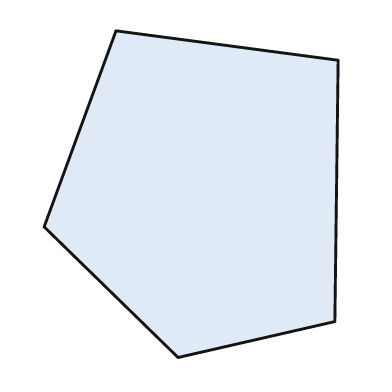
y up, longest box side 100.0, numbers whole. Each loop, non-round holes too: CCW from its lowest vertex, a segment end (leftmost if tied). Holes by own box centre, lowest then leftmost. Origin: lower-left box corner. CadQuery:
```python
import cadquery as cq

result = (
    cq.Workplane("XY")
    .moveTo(41.0, 0.0)
    .lineTo(89.0, 11.0)
    .lineTo(90.0, 91.0)
    .lineTo(22.0, 100.0)
    .lineTo(0.0, 40.0)
    .close()
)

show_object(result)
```